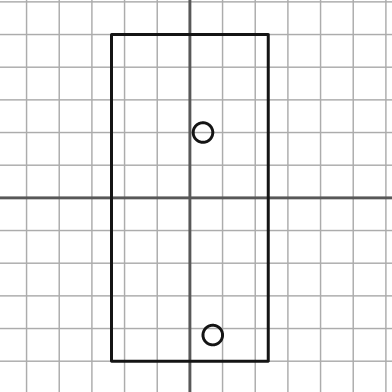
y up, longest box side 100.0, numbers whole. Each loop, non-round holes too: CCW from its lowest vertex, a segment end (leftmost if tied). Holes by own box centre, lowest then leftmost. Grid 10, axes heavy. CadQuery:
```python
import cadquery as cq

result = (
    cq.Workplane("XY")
    .moveTo(-24.0, -50.0)
    .lineTo(24.0, -50.0)
    .lineTo(24.0, 50.0)
    .lineTo(-24.0, 50.0)
    .close()
    .moveTo(7.0, -42.0)
    .circle(3.0)
    .moveTo(4.0, 20.0)
    .circle(3.0)
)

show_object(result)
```